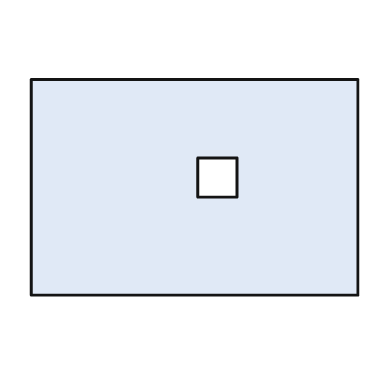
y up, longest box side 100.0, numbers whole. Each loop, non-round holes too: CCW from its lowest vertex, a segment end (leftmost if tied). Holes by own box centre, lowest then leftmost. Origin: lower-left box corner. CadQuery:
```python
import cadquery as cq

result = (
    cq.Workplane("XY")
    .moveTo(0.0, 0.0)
    .lineTo(100.0, 0.0)
    .lineTo(100.0, 66.0)
    .lineTo(0.0, 66.0)
    .close()
    .moveTo(51.0, 30.0)
    .lineTo(63.0, 30.0)
    .lineTo(63.0, 42.0)
    .lineTo(51.0, 42.0)
    .close()
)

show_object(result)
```